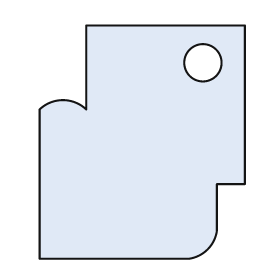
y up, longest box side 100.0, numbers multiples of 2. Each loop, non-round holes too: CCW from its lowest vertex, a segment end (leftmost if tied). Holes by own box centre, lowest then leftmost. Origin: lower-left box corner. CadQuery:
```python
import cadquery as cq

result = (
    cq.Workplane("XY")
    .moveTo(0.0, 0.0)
    .lineTo(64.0, 0.0)
    .threePointArc((72.0, 4.0), (76.0, 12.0))
    .lineTo(76.0, 32.0)
    .lineTo(88.0, 32.0)
    .lineTo(88.0, 100.0)
    .lineTo(20.0, 100.0)
    .lineTo(20.0, 64.0)
    .threePointArc((10.0, 68.0), (0.0, 64.0))
    .close()
    .moveTo(70.0, 84.0)
    .circle(8.0)
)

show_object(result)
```